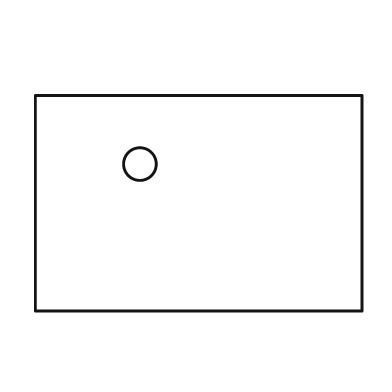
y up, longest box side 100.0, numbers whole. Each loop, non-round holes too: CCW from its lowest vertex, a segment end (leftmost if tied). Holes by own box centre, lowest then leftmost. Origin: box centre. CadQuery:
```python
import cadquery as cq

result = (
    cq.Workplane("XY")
    .moveTo(-50.0, -33.0)
    .lineTo(50.0, -33.0)
    .lineTo(50.0, 33.0)
    .lineTo(-50.0, 33.0)
    .close()
    .moveTo(-18.0, 12.0)
    .circle(5.0)
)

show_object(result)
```